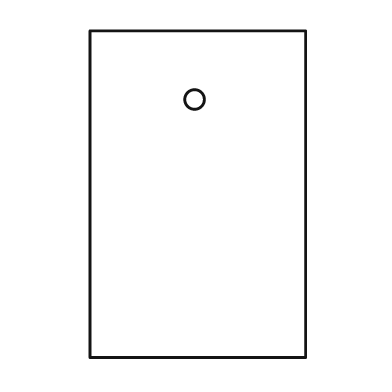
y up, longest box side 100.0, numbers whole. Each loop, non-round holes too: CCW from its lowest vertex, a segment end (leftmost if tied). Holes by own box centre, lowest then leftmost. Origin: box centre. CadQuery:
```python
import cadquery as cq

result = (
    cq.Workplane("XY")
    .moveTo(-33.0, -50.0)
    .lineTo(33.0, -50.0)
    .lineTo(33.0, 50.0)
    .lineTo(-33.0, 50.0)
    .close()
    .moveTo(-1.0, 29.0)
    .circle(3.0)
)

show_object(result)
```